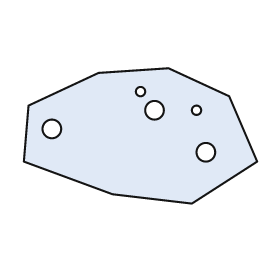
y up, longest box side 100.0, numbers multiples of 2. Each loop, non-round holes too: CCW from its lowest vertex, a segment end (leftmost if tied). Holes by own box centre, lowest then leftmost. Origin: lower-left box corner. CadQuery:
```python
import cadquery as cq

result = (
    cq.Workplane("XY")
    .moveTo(72.0, 0.0)
    .lineTo(100.0, 18.0)
    .lineTo(88.0, 46.0)
    .lineTo(62.0, 58.0)
    .lineTo(32.0, 56.0)
    .lineTo(2.0, 42.0)
    .lineTo(0.0, 18.0)
    .lineTo(38.0, 4.0)
    .close()
    .moveTo(78.0, 22.0)
    .circle(4.0)
    .moveTo(12.0, 32.0)
    .circle(4.0)
    .moveTo(56.0, 40.0)
    .circle(4.0)
    .moveTo(74.0, 40.0)
    .circle(2.0)
    .moveTo(50.0, 48.0)
    .circle(2.0)
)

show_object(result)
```